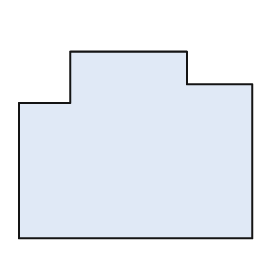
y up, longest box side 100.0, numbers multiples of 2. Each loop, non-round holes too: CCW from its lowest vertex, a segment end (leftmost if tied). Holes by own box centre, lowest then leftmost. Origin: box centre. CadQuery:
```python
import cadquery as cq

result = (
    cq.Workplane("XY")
    .moveTo(-50.0, -40.0)
    .lineTo(50.0, -40.0)
    .lineTo(50.0, 26.0)
    .lineTo(22.0, 26.0)
    .lineTo(22.0, 40.0)
    .lineTo(-28.0, 40.0)
    .lineTo(-28.0, 18.0)
    .lineTo(-50.0, 18.0)
    .close()
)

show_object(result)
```